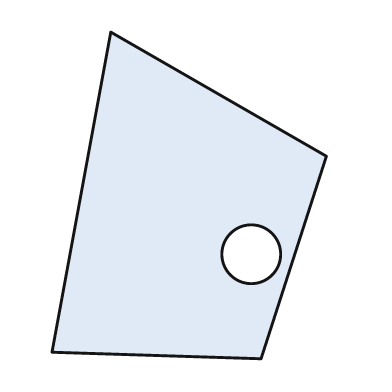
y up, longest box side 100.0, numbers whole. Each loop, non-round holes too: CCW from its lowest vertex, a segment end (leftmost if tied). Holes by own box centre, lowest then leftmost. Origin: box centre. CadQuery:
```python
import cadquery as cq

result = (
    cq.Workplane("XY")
    .moveTo(22.0, -50.0)
    .lineTo(42.0, 12.0)
    .lineTo(-24.0, 50.0)
    .lineTo(-42.0, -48.0)
    .close()
    .moveTo(19.0, -18.0)
    .circle(9.0)
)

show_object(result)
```